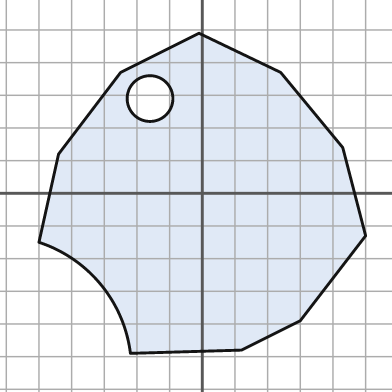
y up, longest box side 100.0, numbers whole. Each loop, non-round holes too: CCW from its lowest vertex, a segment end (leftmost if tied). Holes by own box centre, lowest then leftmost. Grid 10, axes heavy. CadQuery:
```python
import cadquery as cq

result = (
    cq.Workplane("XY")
    .moveTo(-22.0, -49.0)
    .lineTo(12.0, -48.0)
    .lineTo(30.0, -39.0)
    .lineTo(50.0, -13.0)
    .lineTo(43.0, 14.0)
    .lineTo(24.0, 37.0)
    .lineTo(-1.0, 49.0)
    .lineTo(-25.0, 37.0)
    .lineTo(-44.0, 12.0)
    .lineTo(-50.0, -15.0)
    .threePointArc((-31.0, -28.0), (-22.0, -49.0))
    .close()
    .moveTo(-16.0, 29.0)
    .circle(7.0)
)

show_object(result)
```